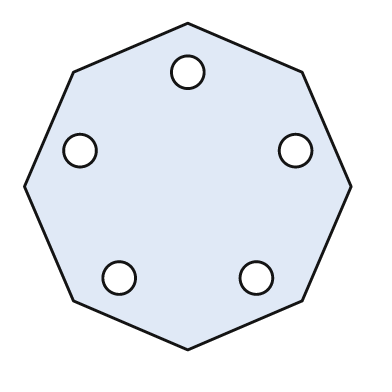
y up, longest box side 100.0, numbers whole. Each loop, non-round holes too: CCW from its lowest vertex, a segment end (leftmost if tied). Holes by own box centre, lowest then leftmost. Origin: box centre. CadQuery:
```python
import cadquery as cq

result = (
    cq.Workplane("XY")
    .moveTo(0.0, -50.0)
    .lineTo(35.0, -35.0)
    .lineTo(50.0, 0.0)
    .lineTo(35.0, 35.0)
    .lineTo(0.0, 50.0)
    .lineTo(-35.0, 35.0)
    .lineTo(-50.0, 0.0)
    .lineTo(-35.0, -35.0)
    .close()
    .moveTo(-21.0, -28.0)
    .circle(5.0)
    .moveTo(21.0, -28.0)
    .circle(5.0)
    .moveTo(-33.0, 11.0)
    .circle(5.0)
    .moveTo(33.0, 11.0)
    .circle(5.0)
    .moveTo(0.0, 35.0)
    .circle(5.0)
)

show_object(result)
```